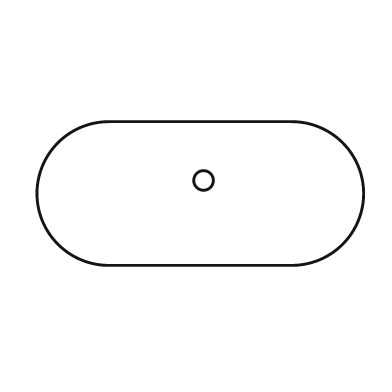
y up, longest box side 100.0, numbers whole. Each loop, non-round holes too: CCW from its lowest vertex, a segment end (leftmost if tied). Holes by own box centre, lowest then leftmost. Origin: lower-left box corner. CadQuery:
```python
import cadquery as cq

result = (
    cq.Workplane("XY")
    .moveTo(22.0, 0.0)
    .lineTo(78.0, 0.0)
    .threePointArc((100.0, 22.0), (78.0, 44.0))
    .lineTo(22.0, 44.0)
    .threePointArc((0.0, 22.0), (22.0, 0.0))
    .close()
    .moveTo(51.0, 26.0)
    .circle(3.0)
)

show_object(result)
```